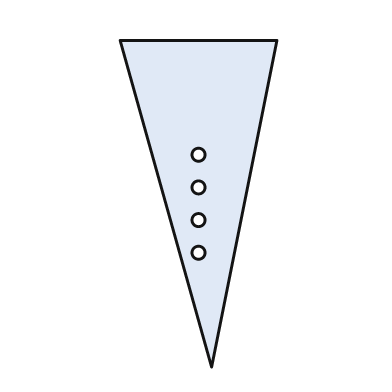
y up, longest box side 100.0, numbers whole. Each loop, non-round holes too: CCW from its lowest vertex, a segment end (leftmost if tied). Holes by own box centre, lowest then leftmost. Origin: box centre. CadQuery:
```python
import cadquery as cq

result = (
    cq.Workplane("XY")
    .moveTo(4.0, -50.0)
    .lineTo(24.0, 50.0)
    .lineTo(-24.0, 50.0)
    .close()
    .moveTo(0.0, -15.0)
    .circle(2.0)
    .moveTo(0.0, -5.0)
    .circle(2.0)
    .moveTo(0.0, 5.0)
    .circle(2.0)
    .moveTo(0.0, 15.0)
    .circle(2.0)
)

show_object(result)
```